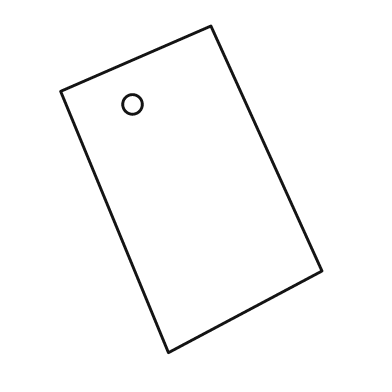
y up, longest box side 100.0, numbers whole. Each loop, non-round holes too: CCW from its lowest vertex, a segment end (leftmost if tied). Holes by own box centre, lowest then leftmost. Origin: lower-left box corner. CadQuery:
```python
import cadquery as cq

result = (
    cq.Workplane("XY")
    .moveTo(33.0, 0.0)
    .lineTo(80.0, 25.0)
    .lineTo(46.0, 100.0)
    .lineTo(0.0, 80.0)
    .close()
    .moveTo(22.0, 76.0)
    .circle(3.0)
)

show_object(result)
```